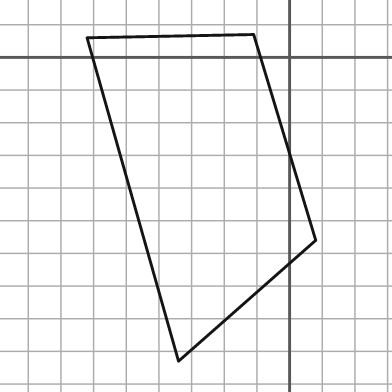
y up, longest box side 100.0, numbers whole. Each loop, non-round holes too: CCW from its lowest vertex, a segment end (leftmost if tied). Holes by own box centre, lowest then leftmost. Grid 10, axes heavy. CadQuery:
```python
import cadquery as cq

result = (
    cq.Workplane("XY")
    .moveTo(-34.0, -93.0)
    .lineTo(8.0, -56.0)
    .lineTo(-11.0, 7.0)
    .lineTo(-62.0, 6.0)
    .close()
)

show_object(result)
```